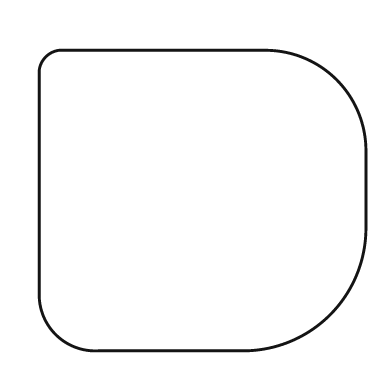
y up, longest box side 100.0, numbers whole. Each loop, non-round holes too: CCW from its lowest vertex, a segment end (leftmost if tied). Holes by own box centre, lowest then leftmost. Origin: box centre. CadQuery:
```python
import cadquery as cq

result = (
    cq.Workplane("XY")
    .moveTo(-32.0, -46.0)
    .lineTo(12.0, -46.0)
    .threePointArc((39.0, -35.0), (50.0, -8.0))
    .lineTo(50.0, 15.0)
    .threePointArc((41.0, 37.0), (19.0, 46.0))
    .lineTo(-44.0, 46.0)
    .threePointArc((-48.0, 44.0), (-50.0, 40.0))
    .lineTo(-50.0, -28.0)
    .threePointArc((-45.0, -41.0), (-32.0, -46.0))
    .close()
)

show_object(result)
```